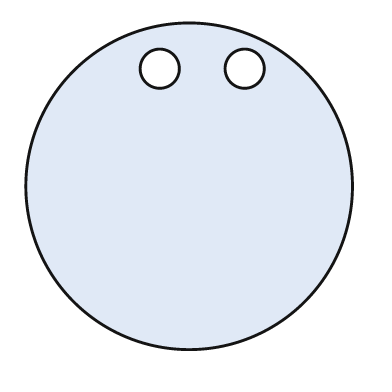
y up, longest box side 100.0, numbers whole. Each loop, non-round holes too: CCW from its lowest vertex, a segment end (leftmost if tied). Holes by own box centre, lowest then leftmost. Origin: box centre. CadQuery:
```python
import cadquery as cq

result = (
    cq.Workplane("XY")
    .moveTo(0.0, 0.0)
    .circle(50.0)
    .moveTo(-9.0, 36.0)
    .circle(6.0)
    .moveTo(17.0, 36.0)
    .circle(6.0)
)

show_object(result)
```